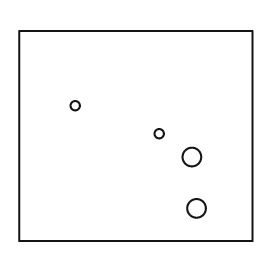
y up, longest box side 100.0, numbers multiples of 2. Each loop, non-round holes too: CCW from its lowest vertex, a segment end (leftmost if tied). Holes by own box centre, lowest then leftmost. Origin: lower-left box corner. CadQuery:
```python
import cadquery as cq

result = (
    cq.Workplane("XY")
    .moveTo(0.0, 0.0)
    .lineTo(100.0, 0.0)
    .lineTo(100.0, 90.0)
    .lineTo(0.0, 90.0)
    .close()
    .moveTo(76.0, 14.0)
    .circle(4.0)
    .moveTo(74.0, 36.0)
    .circle(4.0)
    .moveTo(60.0, 46.0)
    .circle(2.0)
    .moveTo(24.0, 58.0)
    .circle(2.0)
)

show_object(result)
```